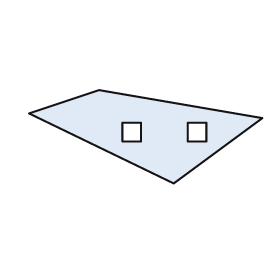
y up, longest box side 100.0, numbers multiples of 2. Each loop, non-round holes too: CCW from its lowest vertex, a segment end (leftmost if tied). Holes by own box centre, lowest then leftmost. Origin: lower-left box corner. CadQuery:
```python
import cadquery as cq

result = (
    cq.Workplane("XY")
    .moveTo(62.0, 0.0)
    .lineTo(100.0, 28.0)
    .lineTo(30.0, 40.0)
    .lineTo(0.0, 30.0)
    .close()
    .moveTo(40.0, 18.0)
    .lineTo(48.0, 18.0)
    .lineTo(48.0, 26.0)
    .lineTo(40.0, 26.0)
    .close()
    .moveTo(68.0, 18.0)
    .lineTo(76.0, 18.0)
    .lineTo(76.0, 26.0)
    .lineTo(68.0, 26.0)
    .close()
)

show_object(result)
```